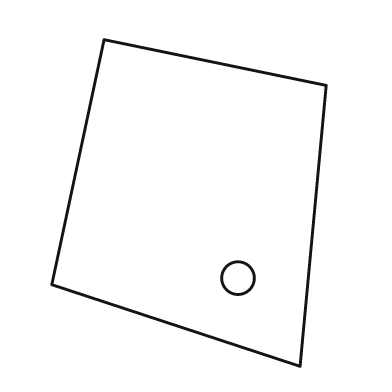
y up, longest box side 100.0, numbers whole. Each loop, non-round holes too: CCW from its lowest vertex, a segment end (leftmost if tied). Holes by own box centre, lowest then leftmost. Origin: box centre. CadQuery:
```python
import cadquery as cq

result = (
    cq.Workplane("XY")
    .moveTo(34.0, -50.0)
    .lineTo(42.0, 36.0)
    .lineTo(-26.0, 50.0)
    .lineTo(-42.0, -25.0)
    .close()
    .moveTo(15.0, -23.0)
    .circle(5.0)
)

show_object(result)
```